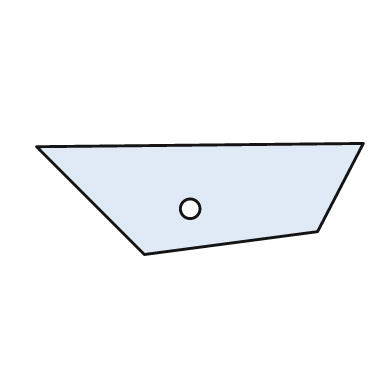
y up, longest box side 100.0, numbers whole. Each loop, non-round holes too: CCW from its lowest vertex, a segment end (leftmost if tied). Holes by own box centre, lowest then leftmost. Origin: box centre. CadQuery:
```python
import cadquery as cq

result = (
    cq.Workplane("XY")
    .moveTo(-17.0, -17.0)
    .lineTo(36.0, -10.0)
    .lineTo(50.0, 17.0)
    .lineTo(-50.0, 16.0)
    .close()
    .moveTo(-3.0, -3.0)
    .circle(3.0)
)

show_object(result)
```